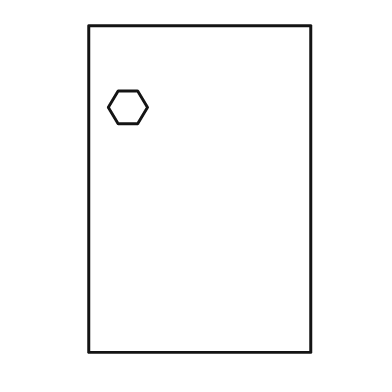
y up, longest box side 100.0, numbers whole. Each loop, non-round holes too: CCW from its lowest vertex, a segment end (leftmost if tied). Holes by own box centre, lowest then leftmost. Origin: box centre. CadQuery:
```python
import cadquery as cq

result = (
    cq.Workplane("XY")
    .moveTo(-34.0, -50.0)
    .lineTo(34.0, -50.0)
    .lineTo(34.0, 50.0)
    .lineTo(-34.0, 50.0)
    .close()
    .moveTo(-25.0, 20.0)
    .lineTo(-19.0, 20.0)
    .lineTo(-16.0, 25.0)
    .lineTo(-19.0, 30.0)
    .lineTo(-25.0, 30.0)
    .lineTo(-28.0, 25.0)
    .close()
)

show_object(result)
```